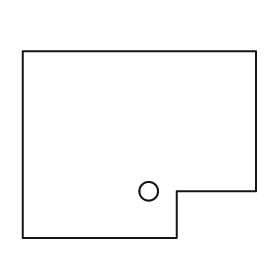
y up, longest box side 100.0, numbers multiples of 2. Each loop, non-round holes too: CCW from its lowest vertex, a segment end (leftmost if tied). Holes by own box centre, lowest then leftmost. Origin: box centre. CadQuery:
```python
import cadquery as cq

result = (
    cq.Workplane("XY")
    .moveTo(-50.0, -40.0)
    .lineTo(16.0, -40.0)
    .lineTo(16.0, -20.0)
    .lineTo(50.0, -20.0)
    .lineTo(50.0, 40.0)
    .lineTo(-50.0, 40.0)
    .close()
    .moveTo(4.0, -20.0)
    .circle(4.0)
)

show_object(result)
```